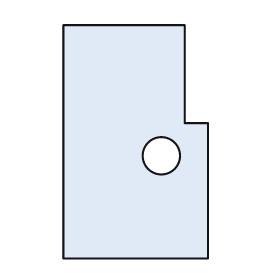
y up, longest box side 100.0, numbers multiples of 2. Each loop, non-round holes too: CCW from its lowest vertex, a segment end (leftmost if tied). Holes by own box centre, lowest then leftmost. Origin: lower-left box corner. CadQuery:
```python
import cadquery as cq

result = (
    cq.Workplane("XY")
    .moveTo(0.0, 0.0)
    .lineTo(62.0, 0.0)
    .lineTo(62.0, 58.0)
    .lineTo(52.0, 58.0)
    .lineTo(52.0, 100.0)
    .lineTo(0.0, 100.0)
    .close()
    .moveTo(42.0, 44.0)
    .circle(8.0)
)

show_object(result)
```